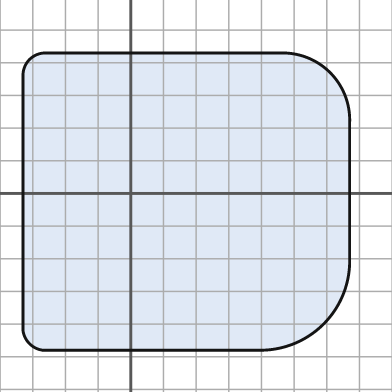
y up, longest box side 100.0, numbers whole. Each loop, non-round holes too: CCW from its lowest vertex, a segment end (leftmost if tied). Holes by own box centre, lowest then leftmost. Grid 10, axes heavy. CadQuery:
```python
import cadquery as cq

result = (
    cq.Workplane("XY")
    .moveTo(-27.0, -48.0)
    .lineTo(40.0, -48.0)
    .threePointArc((59.0, -40.0), (67.0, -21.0))
    .lineTo(67.0, 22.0)
    .threePointArc((61.0, 37.0), (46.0, 43.0))
    .lineTo(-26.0, 43.0)
    .threePointArc((-31.0, 41.0), (-33.0, 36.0))
    .lineTo(-33.0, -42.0)
    .threePointArc((-31.0, -46.0), (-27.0, -48.0))
    .close()
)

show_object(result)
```